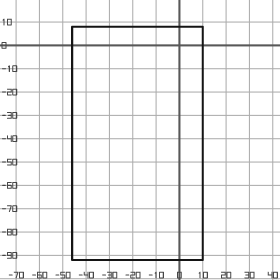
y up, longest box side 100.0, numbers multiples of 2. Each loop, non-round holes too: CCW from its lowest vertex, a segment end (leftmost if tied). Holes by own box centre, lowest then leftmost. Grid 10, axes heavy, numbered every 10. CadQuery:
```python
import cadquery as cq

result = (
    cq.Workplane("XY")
    .moveTo(-46.0, -92.0)
    .lineTo(10.0, -92.0)
    .lineTo(10.0, 8.0)
    .lineTo(-46.0, 8.0)
    .close()
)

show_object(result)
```